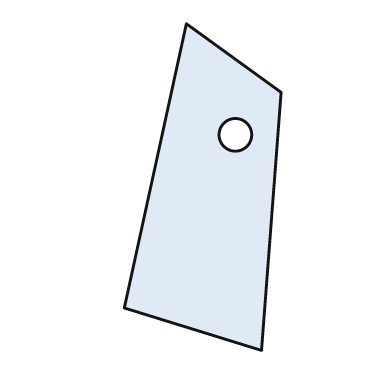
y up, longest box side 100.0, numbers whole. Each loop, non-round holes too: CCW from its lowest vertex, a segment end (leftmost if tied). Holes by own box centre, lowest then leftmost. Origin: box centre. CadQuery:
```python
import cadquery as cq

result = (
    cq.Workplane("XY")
    .moveTo(18.0, -50.0)
    .lineTo(24.0, 29.0)
    .lineTo(-5.0, 50.0)
    .lineTo(-24.0, -37.0)
    .close()
    .moveTo(10.0, 16.0)
    .circle(5.0)
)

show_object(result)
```